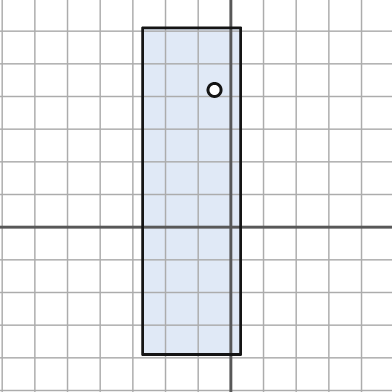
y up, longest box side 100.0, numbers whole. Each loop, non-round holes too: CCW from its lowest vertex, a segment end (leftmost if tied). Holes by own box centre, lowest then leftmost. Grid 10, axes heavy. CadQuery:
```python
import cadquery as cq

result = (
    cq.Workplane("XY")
    .moveTo(-27.0, -39.0)
    .lineTo(3.0, -39.0)
    .lineTo(3.0, 61.0)
    .lineTo(-27.0, 61.0)
    .close()
    .moveTo(-5.0, 42.0)
    .circle(2.0)
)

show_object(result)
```